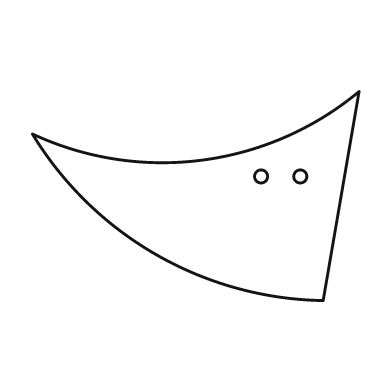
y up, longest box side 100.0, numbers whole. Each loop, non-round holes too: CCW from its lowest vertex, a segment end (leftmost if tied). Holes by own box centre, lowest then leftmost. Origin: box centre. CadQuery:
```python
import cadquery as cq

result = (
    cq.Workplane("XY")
    .moveTo(39.0, -32.0)
    .lineTo(50.0, 32.0)
    .threePointArc((2.0, 11.0), (-50.0, 19.0))
    .threePointArc((-12.0, -18.0), (39.0, -32.0))
    .close()
    .moveTo(20.0, 6.0)
    .circle(2.0)
    .moveTo(32.0, 6.0)
    .circle(2.0)
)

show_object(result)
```